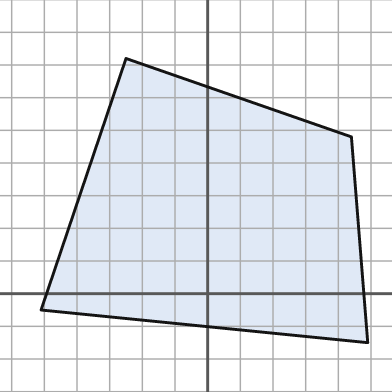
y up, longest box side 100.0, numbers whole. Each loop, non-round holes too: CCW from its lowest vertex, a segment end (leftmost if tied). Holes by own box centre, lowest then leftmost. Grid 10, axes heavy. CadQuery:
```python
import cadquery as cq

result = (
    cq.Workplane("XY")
    .moveTo(49.0, -15.0)
    .lineTo(44.0, 48.0)
    .lineTo(-25.0, 72.0)
    .lineTo(-51.0, -5.0)
    .close()
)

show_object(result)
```